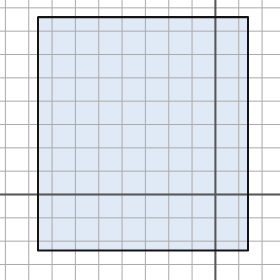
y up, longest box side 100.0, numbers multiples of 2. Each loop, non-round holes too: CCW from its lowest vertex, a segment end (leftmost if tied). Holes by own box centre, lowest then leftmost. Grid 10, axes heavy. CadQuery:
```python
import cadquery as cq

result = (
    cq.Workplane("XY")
    .moveTo(-76.0, -24.0)
    .lineTo(14.0, -24.0)
    .lineTo(14.0, 76.0)
    .lineTo(-76.0, 76.0)
    .close()
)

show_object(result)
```